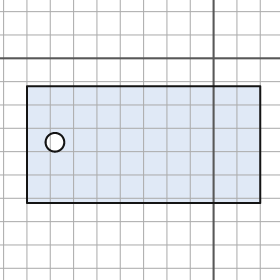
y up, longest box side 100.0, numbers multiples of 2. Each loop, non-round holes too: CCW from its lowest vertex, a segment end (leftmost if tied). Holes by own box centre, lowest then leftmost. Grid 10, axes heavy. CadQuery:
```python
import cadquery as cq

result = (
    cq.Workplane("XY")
    .moveTo(-80.0, -62.0)
    .lineTo(20.0, -62.0)
    .lineTo(20.0, -12.0)
    .lineTo(-80.0, -12.0)
    .close()
    .moveTo(-68.0, -36.0)
    .circle(4.0)
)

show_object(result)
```